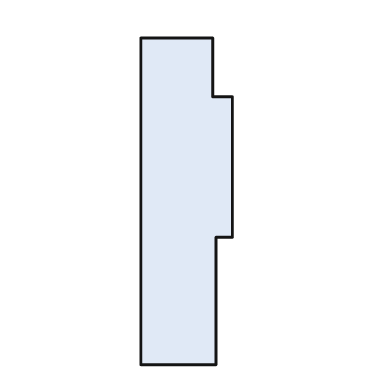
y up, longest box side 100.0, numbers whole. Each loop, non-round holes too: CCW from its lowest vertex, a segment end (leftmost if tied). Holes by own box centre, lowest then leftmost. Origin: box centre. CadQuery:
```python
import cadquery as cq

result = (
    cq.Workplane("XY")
    .moveTo(-14.0, -50.0)
    .lineTo(9.0, -50.0)
    .lineTo(9.0, -11.0)
    .lineTo(14.0, -11.0)
    .lineTo(14.0, 32.0)
    .lineTo(8.0, 32.0)
    .lineTo(8.0, 50.0)
    .lineTo(-14.0, 50.0)
    .close()
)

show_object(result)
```